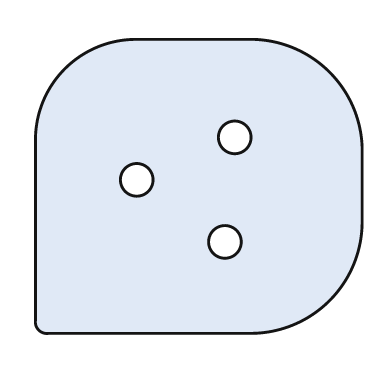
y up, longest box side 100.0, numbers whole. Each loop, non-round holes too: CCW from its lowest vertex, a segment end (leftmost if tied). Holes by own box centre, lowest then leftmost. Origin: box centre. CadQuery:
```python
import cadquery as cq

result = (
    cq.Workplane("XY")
    .moveTo(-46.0, -45.0)
    .lineTo(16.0, -45.0)
    .threePointArc((40.0, -35.0), (50.0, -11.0))
    .lineTo(50.0, 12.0)
    .threePointArc((40.0, 35.0), (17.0, 45.0))
    .lineTo(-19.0, 45.0)
    .threePointArc((-41.0, 36.0), (-50.0, 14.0))
    .lineTo(-50.0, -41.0)
    .threePointArc((-49.0, -44.0), (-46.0, -45.0))
    .close()
    .moveTo(8.0, -17.0)
    .circle(5.0)
    .moveTo(-19.0, 2.0)
    .circle(5.0)
    .moveTo(11.0, 15.0)
    .circle(5.0)
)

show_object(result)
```